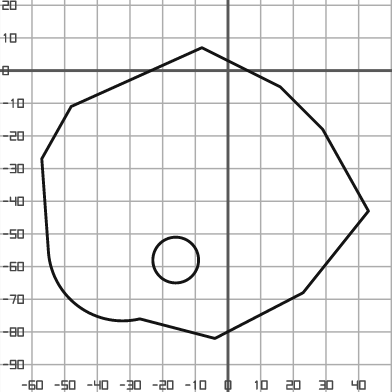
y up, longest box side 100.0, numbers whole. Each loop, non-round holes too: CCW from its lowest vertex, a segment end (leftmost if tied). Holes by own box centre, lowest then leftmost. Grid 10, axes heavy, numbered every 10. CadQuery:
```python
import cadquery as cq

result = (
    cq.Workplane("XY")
    .moveTo(-4.0, -82.0)
    .lineTo(23.0, -68.0)
    .lineTo(43.0, -43.0)
    .lineTo(29.0, -18.0)
    .lineTo(16.0, -5.0)
    .lineTo(-8.0, 7.0)
    .lineTo(-48.0, -11.0)
    .lineTo(-57.0, -27.0)
    .lineTo(-55.0, -55.0)
    .threePointArc((-46.0, -72.0), (-27.0, -76.0))
    .close()
    .moveTo(-16.0, -58.0)
    .circle(7.0)
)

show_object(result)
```